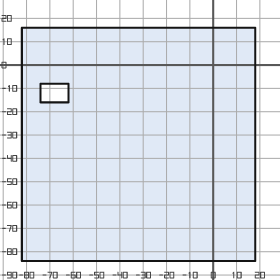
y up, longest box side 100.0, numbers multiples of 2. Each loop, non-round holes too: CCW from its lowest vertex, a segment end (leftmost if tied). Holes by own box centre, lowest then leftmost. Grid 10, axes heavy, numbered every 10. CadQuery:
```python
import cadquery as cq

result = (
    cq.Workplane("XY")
    .moveTo(-82.0, -84.0)
    .lineTo(18.0, -84.0)
    .lineTo(18.0, 16.0)
    .lineTo(-82.0, 16.0)
    .close()
    .moveTo(-74.0, -16.0)
    .lineTo(-62.0, -16.0)
    .lineTo(-62.0, -8.0)
    .lineTo(-74.0, -8.0)
    .close()
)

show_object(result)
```